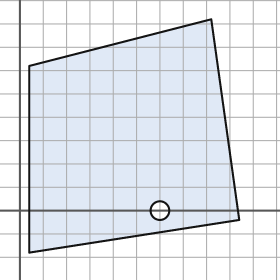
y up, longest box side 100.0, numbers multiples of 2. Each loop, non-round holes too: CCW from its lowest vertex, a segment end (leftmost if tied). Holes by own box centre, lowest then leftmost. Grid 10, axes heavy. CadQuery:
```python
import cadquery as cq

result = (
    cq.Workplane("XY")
    .moveTo(4.0, -18.0)
    .lineTo(94.0, -4.0)
    .lineTo(82.0, 82.0)
    .lineTo(4.0, 62.0)
    .close()
    .moveTo(60.0, 0.0)
    .circle(4.0)
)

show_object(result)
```